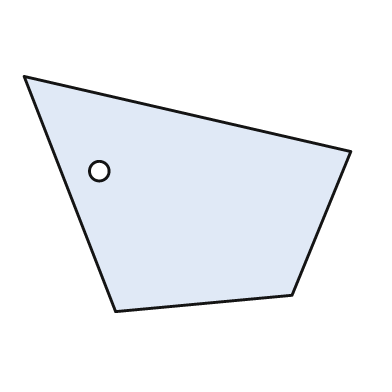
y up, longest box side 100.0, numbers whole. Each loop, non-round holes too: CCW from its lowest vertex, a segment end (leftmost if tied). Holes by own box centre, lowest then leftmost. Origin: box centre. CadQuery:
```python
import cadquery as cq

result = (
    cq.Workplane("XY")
    .moveTo(-22.0, -36.0)
    .lineTo(32.0, -31.0)
    .lineTo(50.0, 13.0)
    .lineTo(-50.0, 36.0)
    .close()
    .moveTo(-27.0, 7.0)
    .circle(3.0)
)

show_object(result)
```